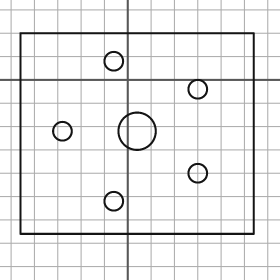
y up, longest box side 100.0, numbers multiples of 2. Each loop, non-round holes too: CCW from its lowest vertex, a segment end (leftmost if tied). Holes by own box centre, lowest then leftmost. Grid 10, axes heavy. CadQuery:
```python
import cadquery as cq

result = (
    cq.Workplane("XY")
    .moveTo(-46.0, -66.0)
    .lineTo(54.0, -66.0)
    .lineTo(54.0, 20.0)
    .lineTo(-46.0, 20.0)
    .close()
    .moveTo(-6.0, -52.0)
    .circle(4.0)
    .moveTo(30.0, -40.0)
    .circle(4.0)
    .moveTo(-28.0, -22.0)
    .circle(4.0)
    .moveTo(4.0, -22.0)
    .circle(8.0)
    .moveTo(30.0, -4.0)
    .circle(4.0)
    .moveTo(-6.0, 8.0)
    .circle(4.0)
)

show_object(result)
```